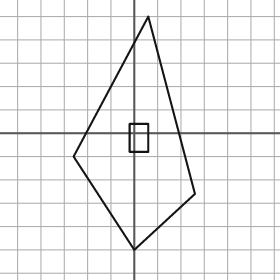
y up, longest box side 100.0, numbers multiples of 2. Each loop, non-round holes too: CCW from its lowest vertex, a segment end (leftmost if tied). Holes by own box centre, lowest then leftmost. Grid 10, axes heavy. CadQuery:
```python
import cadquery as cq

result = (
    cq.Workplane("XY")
    .moveTo(0.0, -50.0)
    .lineTo(26.0, -26.0)
    .lineTo(6.0, 50.0)
    .lineTo(-26.0, -10.0)
    .close()
    .moveTo(-2.0, -8.0)
    .lineTo(6.0, -8.0)
    .lineTo(6.0, 4.0)
    .lineTo(-2.0, 4.0)
    .close()
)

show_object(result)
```